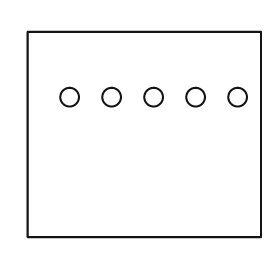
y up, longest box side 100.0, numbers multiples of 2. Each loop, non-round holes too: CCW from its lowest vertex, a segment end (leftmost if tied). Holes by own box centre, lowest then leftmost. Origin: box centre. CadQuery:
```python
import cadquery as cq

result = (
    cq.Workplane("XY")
    .moveTo(-50.0, -44.0)
    .lineTo(50.0, -44.0)
    .lineTo(50.0, 44.0)
    .lineTo(-50.0, 44.0)
    .close()
    .moveTo(-32.0, 16.0)
    .circle(4.0)
    .moveTo(-14.0, 16.0)
    .circle(4.0)
    .moveTo(4.0, 16.0)
    .circle(4.0)
    .moveTo(22.0, 16.0)
    .circle(4.0)
    .moveTo(40.0, 16.0)
    .circle(4.0)
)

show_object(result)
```